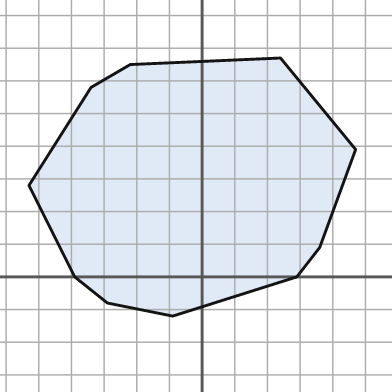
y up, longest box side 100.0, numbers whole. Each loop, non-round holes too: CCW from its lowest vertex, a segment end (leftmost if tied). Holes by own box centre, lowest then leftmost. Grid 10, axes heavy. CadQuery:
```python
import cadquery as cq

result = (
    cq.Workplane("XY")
    .moveTo(-9.0, -12.0)
    .lineTo(29.0, 0.0)
    .lineTo(36.0, 9.0)
    .lineTo(47.0, 39.0)
    .lineTo(24.0, 67.0)
    .lineTo(-22.0, 65.0)
    .lineTo(-34.0, 58.0)
    .lineTo(-53.0, 28.0)
    .lineTo(-39.0, 0.0)
    .lineTo(-29.0, -8.0)
    .close()
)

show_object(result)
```